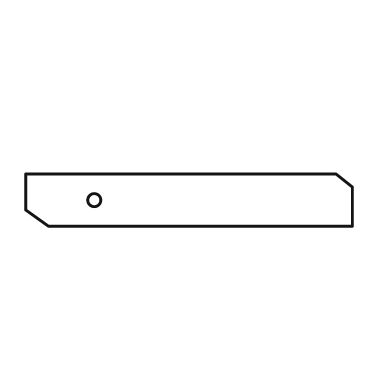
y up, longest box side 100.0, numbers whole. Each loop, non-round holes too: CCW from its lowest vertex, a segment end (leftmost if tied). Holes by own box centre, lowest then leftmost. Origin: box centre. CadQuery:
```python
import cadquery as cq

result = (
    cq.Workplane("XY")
    .moveTo(-43.0, -8.0)
    .lineTo(50.0, -8.0)
    .lineTo(50.0, 4.0)
    .lineTo(45.0, 8.0)
    .lineTo(-50.0, 8.0)
    .lineTo(-50.0, -3.0)
    .close()
    .moveTo(-29.0, 0.0)
    .circle(2.0)
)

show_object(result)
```